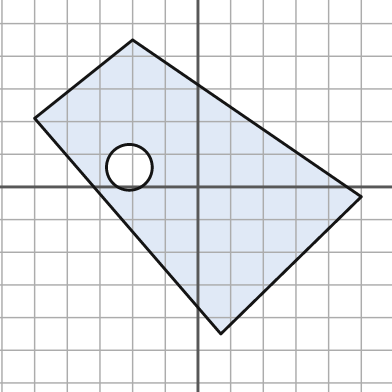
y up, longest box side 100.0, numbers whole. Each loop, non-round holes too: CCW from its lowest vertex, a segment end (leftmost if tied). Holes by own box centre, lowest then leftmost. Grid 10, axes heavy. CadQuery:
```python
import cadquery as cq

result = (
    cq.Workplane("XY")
    .moveTo(7.0, -45.0)
    .lineTo(50.0, -3.0)
    .lineTo(-20.0, 45.0)
    .lineTo(-50.0, 21.0)
    .close()
    .moveTo(-21.0, 6.0)
    .circle(7.0)
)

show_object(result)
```